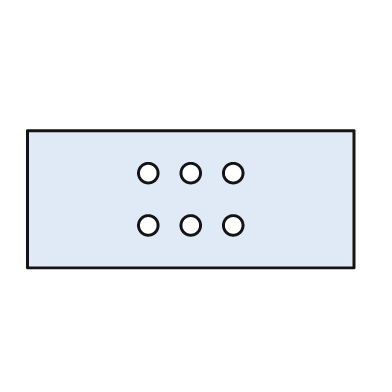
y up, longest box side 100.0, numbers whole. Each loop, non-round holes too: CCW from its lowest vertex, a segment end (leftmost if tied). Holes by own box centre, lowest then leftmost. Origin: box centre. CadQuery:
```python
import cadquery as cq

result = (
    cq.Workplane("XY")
    .moveTo(-50.0, -21.0)
    .lineTo(50.0, -21.0)
    .lineTo(50.0, 21.0)
    .lineTo(-50.0, 21.0)
    .close()
    .moveTo(-13.0, -8.0)
    .circle(3.0)
    .moveTo(0.0, -8.0)
    .circle(3.0)
    .moveTo(13.0, -8.0)
    .circle(3.0)
    .moveTo(-13.0, 8.0)
    .circle(3.0)
    .moveTo(0.0, 8.0)
    .circle(3.0)
    .moveTo(13.0, 8.0)
    .circle(3.0)
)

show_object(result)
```